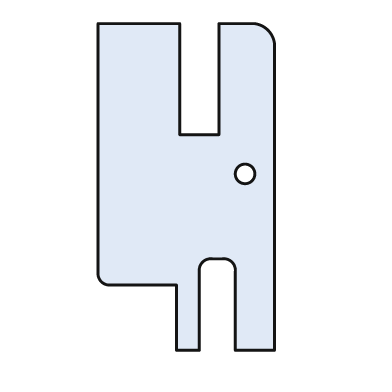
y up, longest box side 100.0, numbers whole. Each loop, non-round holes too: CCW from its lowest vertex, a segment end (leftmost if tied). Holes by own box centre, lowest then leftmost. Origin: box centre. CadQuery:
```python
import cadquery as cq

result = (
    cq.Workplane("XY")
    .moveTo(-3.0, -50.0)
    .lineTo(4.0, -50.0)
    .lineTo(4.0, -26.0)
    .threePointArc((5.0, -23.0), (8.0, -22.0))
    .lineTo(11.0, -22.0)
    .threePointArc((14.0, -23.0), (15.0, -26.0))
    .lineTo(15.0, -50.0)
    .lineTo(27.0, -50.0)
    .lineTo(27.0, 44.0)
    .threePointArc((25.0, 48.0), (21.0, 50.0))
    .lineTo(10.0, 50.0)
    .lineTo(10.0, 16.0)
    .lineTo(-2.0, 16.0)
    .lineTo(-2.0, 50.0)
    .lineTo(-27.0, 50.0)
    .lineTo(-27.0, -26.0)
    .threePointArc((-26.0, -29.0), (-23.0, -30.0))
    .lineTo(-3.0, -30.0)
    .close()
    .moveTo(18.0, 4.0)
    .circle(3.0)
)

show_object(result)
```